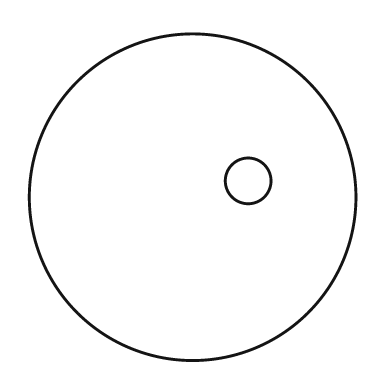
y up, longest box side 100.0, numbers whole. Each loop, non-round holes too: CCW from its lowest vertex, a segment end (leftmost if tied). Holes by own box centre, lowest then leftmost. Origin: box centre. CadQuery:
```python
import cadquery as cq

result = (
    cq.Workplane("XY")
    .moveTo(0.0, 0.0)
    .circle(50.0)
    .moveTo(17.0, 5.0)
    .circle(7.0)
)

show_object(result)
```